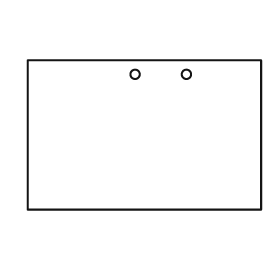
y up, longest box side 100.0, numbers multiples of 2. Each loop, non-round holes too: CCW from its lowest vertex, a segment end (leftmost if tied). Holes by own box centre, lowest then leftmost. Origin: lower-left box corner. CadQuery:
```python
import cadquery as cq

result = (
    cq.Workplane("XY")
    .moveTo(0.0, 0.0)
    .lineTo(100.0, 0.0)
    .lineTo(100.0, 64.0)
    .lineTo(0.0, 64.0)
    .close()
    .moveTo(46.0, 58.0)
    .circle(2.0)
    .moveTo(68.0, 58.0)
    .circle(2.0)
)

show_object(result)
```